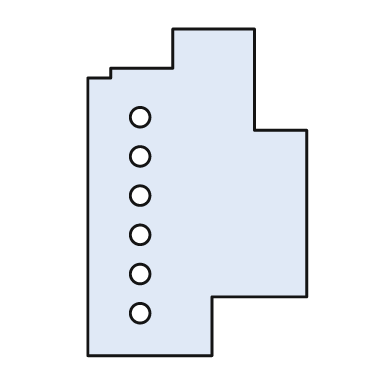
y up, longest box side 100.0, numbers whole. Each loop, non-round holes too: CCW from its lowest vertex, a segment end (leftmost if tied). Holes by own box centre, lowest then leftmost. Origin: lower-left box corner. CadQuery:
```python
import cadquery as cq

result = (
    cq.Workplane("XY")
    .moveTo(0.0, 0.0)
    .lineTo(38.0, 0.0)
    .lineTo(38.0, 18.0)
    .lineTo(67.0, 18.0)
    .lineTo(67.0, 69.0)
    .lineTo(51.0, 69.0)
    .lineTo(51.0, 100.0)
    .lineTo(26.0, 100.0)
    .lineTo(26.0, 88.0)
    .lineTo(7.0, 88.0)
    .lineTo(7.0, 85.0)
    .lineTo(0.0, 85.0)
    .close()
    .moveTo(16.0, 13.0)
    .circle(3.0)
    .moveTo(16.0, 25.0)
    .circle(3.0)
    .moveTo(16.0, 37.0)
    .circle(3.0)
    .moveTo(16.0, 49.0)
    .circle(3.0)
    .moveTo(16.0, 61.0)
    .circle(3.0)
    .moveTo(16.0, 73.0)
    .circle(3.0)
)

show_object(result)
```